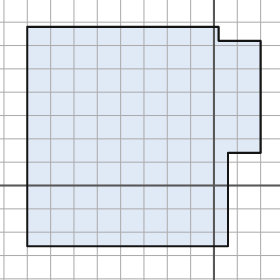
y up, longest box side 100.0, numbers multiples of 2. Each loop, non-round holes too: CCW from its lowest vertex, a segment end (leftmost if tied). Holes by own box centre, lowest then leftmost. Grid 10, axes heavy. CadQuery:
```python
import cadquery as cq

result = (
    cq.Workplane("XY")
    .moveTo(-80.0, -26.0)
    .lineTo(6.0, -26.0)
    .lineTo(6.0, 14.0)
    .lineTo(20.0, 14.0)
    .lineTo(20.0, 62.0)
    .lineTo(2.0, 62.0)
    .lineTo(2.0, 68.0)
    .lineTo(-80.0, 68.0)
    .close()
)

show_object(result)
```